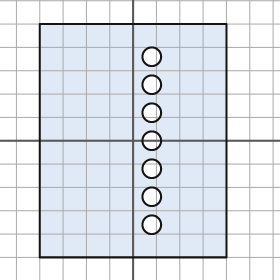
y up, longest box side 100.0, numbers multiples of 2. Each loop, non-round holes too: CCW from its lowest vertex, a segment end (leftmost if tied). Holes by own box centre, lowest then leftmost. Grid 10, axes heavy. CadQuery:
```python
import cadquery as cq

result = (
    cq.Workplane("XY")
    .moveTo(-40.0, -50.0)
    .lineTo(40.0, -50.0)
    .lineTo(40.0, 50.0)
    .lineTo(-40.0, 50.0)
    .close()
    .moveTo(8.0, -36.0)
    .circle(4.0)
    .moveTo(8.0, -24.0)
    .circle(4.0)
    .moveTo(8.0, -12.0)
    .circle(4.0)
    .moveTo(8.0, 0.0)
    .circle(4.0)
    .moveTo(8.0, 12.0)
    .circle(4.0)
    .moveTo(8.0, 24.0)
    .circle(4.0)
    .moveTo(8.0, 36.0)
    .circle(4.0)
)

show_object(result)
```